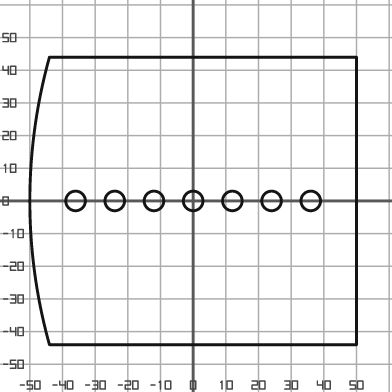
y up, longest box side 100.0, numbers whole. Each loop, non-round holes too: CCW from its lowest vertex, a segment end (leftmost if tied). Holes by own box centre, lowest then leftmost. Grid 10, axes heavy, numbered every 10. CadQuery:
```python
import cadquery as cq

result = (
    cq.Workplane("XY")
    .moveTo(-44.0, -44.0)
    .lineTo(50.0, -44.0)
    .lineTo(50.0, 44.0)
    .lineTo(-44.0, 44.0)
    .threePointArc((-50.0, 0.0), (-44.0, -44.0))
    .close()
    .moveTo(-36.0, 0.0)
    .circle(3.0)
    .moveTo(-24.0, 0.0)
    .circle(3.0)
    .moveTo(-12.0, 0.0)
    .circle(3.0)
    .moveTo(0.0, 0.0)
    .circle(3.0)
    .moveTo(12.0, 0.0)
    .circle(3.0)
    .moveTo(24.0, 0.0)
    .circle(3.0)
    .moveTo(36.0, 0.0)
    .circle(3.0)
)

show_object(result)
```